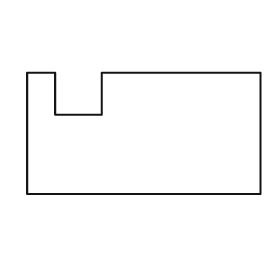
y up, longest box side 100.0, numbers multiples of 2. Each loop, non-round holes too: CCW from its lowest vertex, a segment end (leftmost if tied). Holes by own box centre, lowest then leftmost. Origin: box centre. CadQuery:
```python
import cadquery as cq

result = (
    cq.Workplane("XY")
    .moveTo(-50.0, -26.0)
    .lineTo(50.0, -26.0)
    .lineTo(50.0, 26.0)
    .lineTo(-18.0, 26.0)
    .lineTo(-18.0, 8.0)
    .lineTo(-38.0, 8.0)
    .lineTo(-38.0, 26.0)
    .lineTo(-50.0, 26.0)
    .close()
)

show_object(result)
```